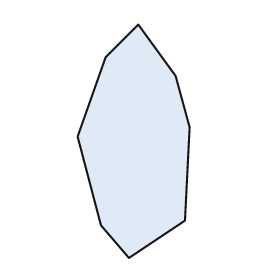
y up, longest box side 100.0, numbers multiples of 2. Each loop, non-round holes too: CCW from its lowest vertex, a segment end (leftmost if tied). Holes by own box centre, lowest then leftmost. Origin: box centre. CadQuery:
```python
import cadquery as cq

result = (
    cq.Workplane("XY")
    .moveTo(-2.0, -50.0)
    .lineTo(22.0, -34.0)
    .lineTo(24.0, 6.0)
    .lineTo(18.0, 28.0)
    .lineTo(2.0, 50.0)
    .lineTo(-12.0, 36.0)
    .lineTo(-24.0, 2.0)
    .lineTo(-14.0, -36.0)
    .close()
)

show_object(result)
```